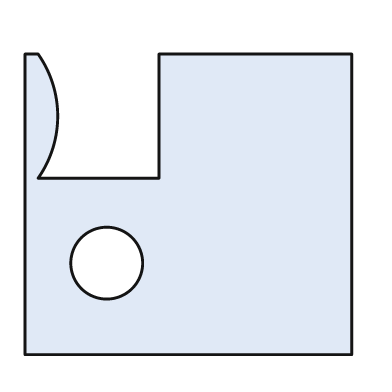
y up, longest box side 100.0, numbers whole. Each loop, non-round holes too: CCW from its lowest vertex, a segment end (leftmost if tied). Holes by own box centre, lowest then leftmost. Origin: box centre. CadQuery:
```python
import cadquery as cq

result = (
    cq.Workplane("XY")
    .moveTo(-50.0, -46.0)
    .lineTo(50.0, -46.0)
    .lineTo(50.0, 46.0)
    .lineTo(-9.0, 46.0)
    .lineTo(-9.0, 8.0)
    .lineTo(-46.0, 8.0)
    .threePointArc((-40.0, 27.0), (-46.0, 46.0))
    .lineTo(-50.0, 46.0)
    .close()
    .moveTo(-25.0, -18.0)
    .circle(11.0)
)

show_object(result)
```